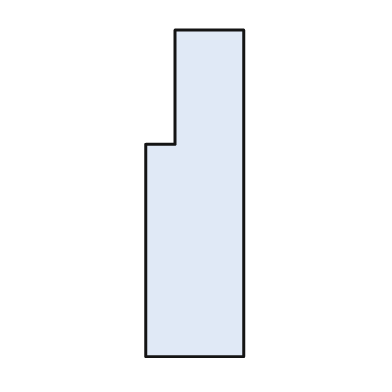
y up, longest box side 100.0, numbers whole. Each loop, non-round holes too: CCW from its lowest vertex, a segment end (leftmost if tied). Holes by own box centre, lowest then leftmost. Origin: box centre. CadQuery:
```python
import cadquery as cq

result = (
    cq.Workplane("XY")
    .moveTo(-15.0, -50.0)
    .lineTo(15.0, -50.0)
    .lineTo(15.0, 50.0)
    .lineTo(-6.0, 50.0)
    .lineTo(-6.0, 15.0)
    .lineTo(-15.0, 15.0)
    .close()
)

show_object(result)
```